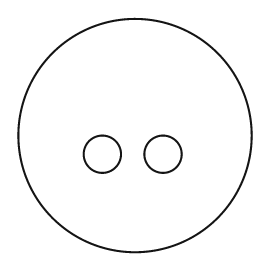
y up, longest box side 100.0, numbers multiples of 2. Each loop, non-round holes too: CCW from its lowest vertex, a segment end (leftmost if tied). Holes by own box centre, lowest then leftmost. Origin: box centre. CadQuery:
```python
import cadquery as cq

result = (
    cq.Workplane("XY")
    .moveTo(0.0, 0.0)
    .circle(50.0)
    .moveTo(-14.0, -8.0)
    .circle(8.0)
    .moveTo(12.0, -8.0)
    .circle(8.0)
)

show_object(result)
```